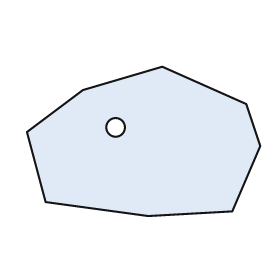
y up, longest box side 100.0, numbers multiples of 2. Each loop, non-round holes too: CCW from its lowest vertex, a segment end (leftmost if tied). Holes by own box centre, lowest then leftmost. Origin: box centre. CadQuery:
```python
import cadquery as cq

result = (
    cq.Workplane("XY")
    .moveTo(2.0, -32.0)
    .lineTo(38.0, -30.0)
    .lineTo(50.0, -2.0)
    .lineTo(44.0, 16.0)
    .lineTo(8.0, 32.0)
    .lineTo(-26.0, 22.0)
    .lineTo(-50.0, 4.0)
    .lineTo(-42.0, -26.0)
    .close()
    .moveTo(-12.0, 6.0)
    .circle(4.0)
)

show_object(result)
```